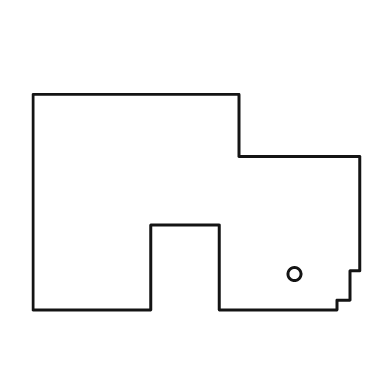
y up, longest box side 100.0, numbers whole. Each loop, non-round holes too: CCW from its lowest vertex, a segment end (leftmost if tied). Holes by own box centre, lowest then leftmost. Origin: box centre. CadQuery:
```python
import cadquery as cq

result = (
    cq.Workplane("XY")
    .moveTo(-50.0, -33.0)
    .lineTo(-14.0, -33.0)
    .lineTo(-14.0, -7.0)
    .lineTo(7.0, -7.0)
    .lineTo(7.0, -33.0)
    .lineTo(43.0, -33.0)
    .lineTo(43.0, -30.0)
    .lineTo(47.0, -30.0)
    .lineTo(47.0, -21.0)
    .lineTo(50.0, -21.0)
    .lineTo(50.0, 14.0)
    .lineTo(13.0, 14.0)
    .lineTo(13.0, 33.0)
    .lineTo(-50.0, 33.0)
    .close()
    .moveTo(30.0, -22.0)
    .circle(2.0)
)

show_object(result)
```